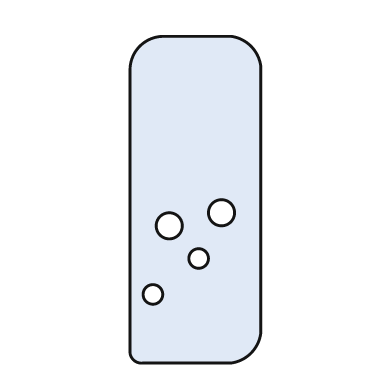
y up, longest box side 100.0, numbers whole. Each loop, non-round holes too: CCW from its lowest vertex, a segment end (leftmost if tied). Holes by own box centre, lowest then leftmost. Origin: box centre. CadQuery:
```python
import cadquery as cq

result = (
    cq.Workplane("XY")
    .moveTo(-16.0, -50.0)
    .lineTo(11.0, -50.0)
    .threePointArc((17.0, -47.0), (20.0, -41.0))
    .lineTo(20.0, 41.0)
    .threePointArc((17.0, 47.0), (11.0, 50.0))
    .lineTo(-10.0, 50.0)
    .threePointArc((-17.0, 47.0), (-20.0, 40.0))
    .lineTo(-20.0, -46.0)
    .threePointArc((-19.0, -49.0), (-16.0, -50.0))
    .close()
    .moveTo(-13.0, -29.0)
    .circle(3.0)
    .moveTo(1.0, -18.0)
    .circle(3.0)
    .moveTo(-8.0, -8.0)
    .circle(4.0)
    .moveTo(8.0, -4.0)
    .circle(4.0)
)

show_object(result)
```